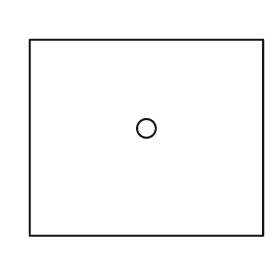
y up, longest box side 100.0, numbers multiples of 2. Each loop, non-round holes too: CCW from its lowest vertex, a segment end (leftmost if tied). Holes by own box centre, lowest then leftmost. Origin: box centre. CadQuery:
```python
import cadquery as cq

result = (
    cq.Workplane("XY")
    .moveTo(-50.0, -42.0)
    .lineTo(50.0, -42.0)
    .lineTo(50.0, 42.0)
    .lineTo(-50.0, 42.0)
    .close()
    .moveTo(0.0, 4.0)
    .circle(4.0)
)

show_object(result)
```